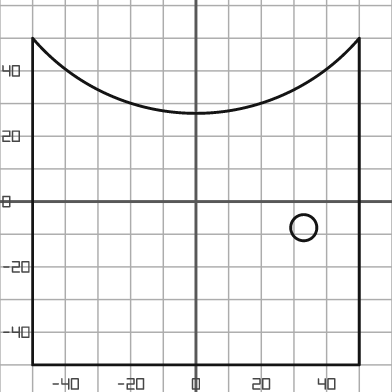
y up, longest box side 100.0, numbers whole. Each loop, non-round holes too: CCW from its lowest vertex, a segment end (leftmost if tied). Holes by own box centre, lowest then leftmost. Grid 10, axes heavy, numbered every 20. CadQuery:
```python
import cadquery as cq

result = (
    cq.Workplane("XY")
    .moveTo(-50.0, -50.0)
    .lineTo(50.0, -50.0)
    .lineTo(50.0, 50.0)
    .threePointArc((0.0, 27.0), (-50.0, 50.0))
    .close()
    .moveTo(33.0, -8.0)
    .circle(4.0)
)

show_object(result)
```